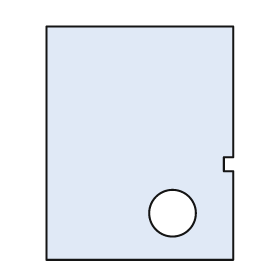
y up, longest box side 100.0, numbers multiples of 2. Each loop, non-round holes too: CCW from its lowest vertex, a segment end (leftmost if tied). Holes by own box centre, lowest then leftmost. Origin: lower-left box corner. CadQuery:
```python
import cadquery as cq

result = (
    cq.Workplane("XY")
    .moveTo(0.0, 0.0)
    .lineTo(80.0, 0.0)
    .lineTo(80.0, 38.0)
    .lineTo(76.0, 38.0)
    .lineTo(76.0, 44.0)
    .lineTo(80.0, 44.0)
    .lineTo(80.0, 100.0)
    .lineTo(0.0, 100.0)
    .close()
    .moveTo(54.0, 20.0)
    .circle(10.0)
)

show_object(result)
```